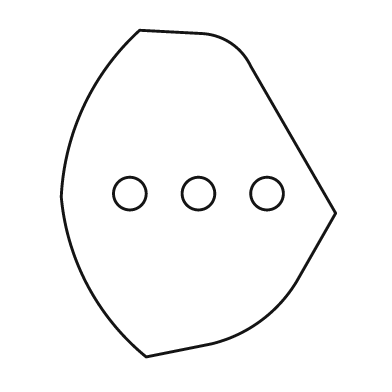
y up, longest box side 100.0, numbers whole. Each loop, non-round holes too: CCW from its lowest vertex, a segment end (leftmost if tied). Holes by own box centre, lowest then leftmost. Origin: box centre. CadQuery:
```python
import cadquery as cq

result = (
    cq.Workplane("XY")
    .moveTo(-16.0, -50.0)
    .lineTo(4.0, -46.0)
    .threePointArc((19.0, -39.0), (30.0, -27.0))
    .lineTo(42.0, -6.0)
    .lineTo(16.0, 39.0)
    .threePointArc((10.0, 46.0), (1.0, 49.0))
    .lineTo(-18.0, 50.0)
    .threePointArc((-35.0, 27.0), (-42.0, -1.0))
    .threePointArc((-34.0, -28.0), (-16.0, -50.0))
    .close()
    .moveTo(-21.0, 0.0)
    .circle(5.0)
    .moveTo(0.0, 0.0)
    .circle(5.0)
    .moveTo(21.0, 0.0)
    .circle(5.0)
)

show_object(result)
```